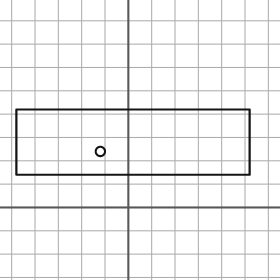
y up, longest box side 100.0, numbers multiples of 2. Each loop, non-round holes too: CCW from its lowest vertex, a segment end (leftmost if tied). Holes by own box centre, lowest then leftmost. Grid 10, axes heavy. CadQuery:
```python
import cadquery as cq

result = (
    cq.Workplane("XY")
    .moveTo(-48.0, 14.0)
    .lineTo(52.0, 14.0)
    .lineTo(52.0, 42.0)
    .lineTo(-48.0, 42.0)
    .close()
    .moveTo(-12.0, 24.0)
    .circle(2.0)
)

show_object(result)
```